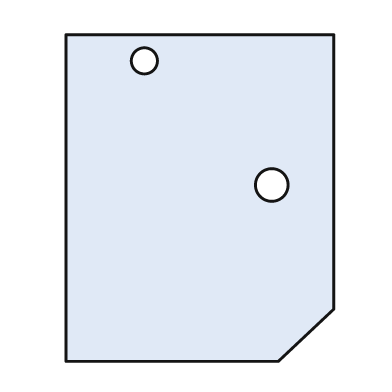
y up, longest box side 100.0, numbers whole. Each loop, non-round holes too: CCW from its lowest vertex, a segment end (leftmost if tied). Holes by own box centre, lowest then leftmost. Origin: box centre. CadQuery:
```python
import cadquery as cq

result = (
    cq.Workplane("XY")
    .moveTo(-41.0, -50.0)
    .lineTo(24.0, -50.0)
    .lineTo(41.0, -34.0)
    .lineTo(41.0, 50.0)
    .lineTo(-41.0, 50.0)
    .close()
    .moveTo(22.0, 4.0)
    .circle(5.0)
    .moveTo(-17.0, 42.0)
    .circle(4.0)
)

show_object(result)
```